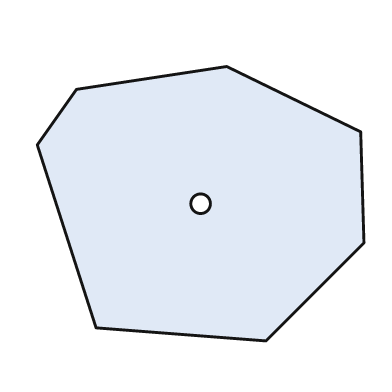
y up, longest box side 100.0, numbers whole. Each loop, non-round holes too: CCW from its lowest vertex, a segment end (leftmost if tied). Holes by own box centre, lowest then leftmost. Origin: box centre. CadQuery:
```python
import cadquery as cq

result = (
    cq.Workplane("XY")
    .moveTo(20.0, -42.0)
    .lineTo(50.0, -12.0)
    .lineTo(49.0, 22.0)
    .lineTo(8.0, 42.0)
    .lineTo(-38.0, 35.0)
    .lineTo(-50.0, 18.0)
    .lineTo(-32.0, -38.0)
    .close()
    .moveTo(0.0, 0.0)
    .circle(3.0)
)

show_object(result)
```